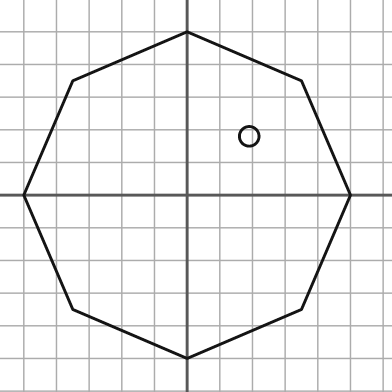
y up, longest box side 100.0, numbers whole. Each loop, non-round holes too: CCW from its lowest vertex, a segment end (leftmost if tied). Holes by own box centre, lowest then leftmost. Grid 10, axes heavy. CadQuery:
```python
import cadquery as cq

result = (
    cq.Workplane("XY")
    .moveTo(0.0, -50.0)
    .lineTo(35.0, -35.0)
    .lineTo(50.0, 0.0)
    .lineTo(35.0, 35.0)
    .lineTo(0.0, 50.0)
    .lineTo(-35.0, 35.0)
    .lineTo(-50.0, 0.0)
    .lineTo(-35.0, -35.0)
    .close()
    .moveTo(19.0, 18.0)
    .circle(3.0)
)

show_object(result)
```